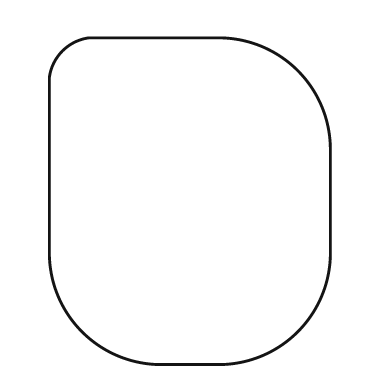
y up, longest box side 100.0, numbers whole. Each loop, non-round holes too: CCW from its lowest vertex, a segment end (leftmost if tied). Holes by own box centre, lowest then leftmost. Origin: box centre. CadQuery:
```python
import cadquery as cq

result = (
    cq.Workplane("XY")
    .moveTo(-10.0, -50.0)
    .lineTo(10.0, -50.0)
    .threePointArc((33.0, -40.0), (43.0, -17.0))
    .lineTo(43.0, 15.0)
    .threePointArc((33.0, 40.0), (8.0, 50.0))
    .lineTo(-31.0, 50.0)
    .threePointArc((-39.0, 46.0), (-43.0, 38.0))
    .lineTo(-43.0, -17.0)
    .threePointArc((-33.0, -40.0), (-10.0, -50.0))
    .close()
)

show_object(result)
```